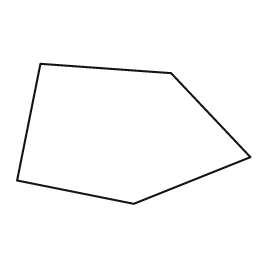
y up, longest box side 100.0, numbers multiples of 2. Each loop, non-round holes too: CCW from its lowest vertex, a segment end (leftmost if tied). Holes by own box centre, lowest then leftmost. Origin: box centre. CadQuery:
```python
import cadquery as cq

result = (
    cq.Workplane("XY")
    .moveTo(0.0, -30.0)
    .lineTo(50.0, -10.0)
    .lineTo(16.0, 26.0)
    .lineTo(-40.0, 30.0)
    .lineTo(-50.0, -20.0)
    .close()
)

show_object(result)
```